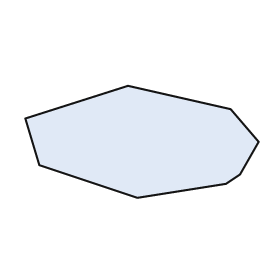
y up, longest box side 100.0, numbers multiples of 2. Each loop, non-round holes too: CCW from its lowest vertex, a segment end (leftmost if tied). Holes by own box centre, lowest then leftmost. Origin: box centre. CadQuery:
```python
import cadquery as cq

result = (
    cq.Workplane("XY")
    .moveTo(-2.0, -24.0)
    .lineTo(36.0, -18.0)
    .lineTo(42.0, -14.0)
    .lineTo(50.0, 0.0)
    .lineTo(38.0, 14.0)
    .lineTo(-6.0, 24.0)
    .lineTo(-50.0, 10.0)
    .lineTo(-44.0, -10.0)
    .close()
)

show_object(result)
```